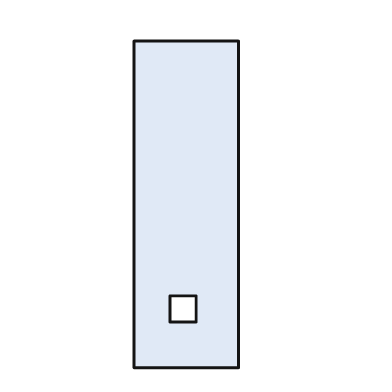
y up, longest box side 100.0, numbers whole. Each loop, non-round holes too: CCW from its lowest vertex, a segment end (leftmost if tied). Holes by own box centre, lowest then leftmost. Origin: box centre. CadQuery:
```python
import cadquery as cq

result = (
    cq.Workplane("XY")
    .moveTo(-16.0, -50.0)
    .lineTo(16.0, -50.0)
    .lineTo(16.0, 50.0)
    .lineTo(-16.0, 50.0)
    .close()
    .moveTo(-5.0, -36.0)
    .lineTo(3.0, -36.0)
    .lineTo(3.0, -28.0)
    .lineTo(-5.0, -28.0)
    .close()
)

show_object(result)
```